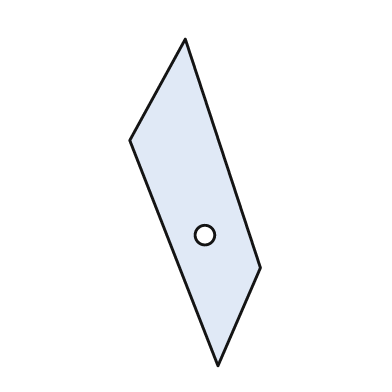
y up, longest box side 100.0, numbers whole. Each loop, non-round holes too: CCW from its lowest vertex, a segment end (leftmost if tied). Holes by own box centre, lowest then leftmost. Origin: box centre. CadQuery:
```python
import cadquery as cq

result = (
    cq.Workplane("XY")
    .moveTo(7.0, -50.0)
    .lineTo(20.0, -20.0)
    .lineTo(-3.0, 50.0)
    .lineTo(-20.0, 19.0)
    .close()
    .moveTo(3.0, -10.0)
    .circle(3.0)
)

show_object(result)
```